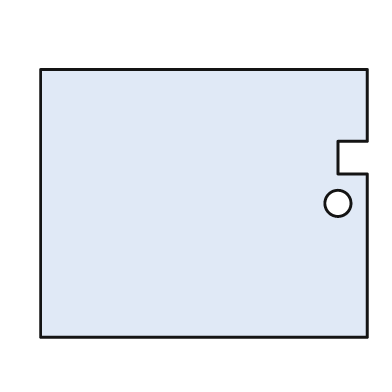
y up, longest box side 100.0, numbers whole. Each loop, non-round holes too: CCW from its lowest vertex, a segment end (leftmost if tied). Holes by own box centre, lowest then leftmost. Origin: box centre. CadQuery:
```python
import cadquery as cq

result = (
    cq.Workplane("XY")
    .moveTo(-50.0, -41.0)
    .lineTo(50.0, -41.0)
    .lineTo(50.0, 9.0)
    .lineTo(41.0, 9.0)
    .lineTo(41.0, 19.0)
    .lineTo(50.0, 19.0)
    .lineTo(50.0, 41.0)
    .lineTo(-50.0, 41.0)
    .close()
    .moveTo(41.0, 0.0)
    .circle(4.0)
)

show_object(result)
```